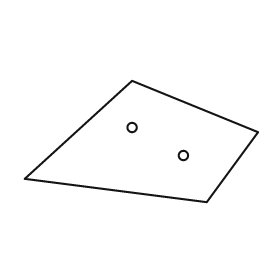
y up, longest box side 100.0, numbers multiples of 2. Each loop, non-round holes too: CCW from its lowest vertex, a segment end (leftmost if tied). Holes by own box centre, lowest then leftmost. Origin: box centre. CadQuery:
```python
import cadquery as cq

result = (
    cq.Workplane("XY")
    .moveTo(28.0, -26.0)
    .lineTo(50.0, 4.0)
    .lineTo(-4.0, 26.0)
    .lineTo(-50.0, -16.0)
    .close()
    .moveTo(18.0, -6.0)
    .circle(2.0)
    .moveTo(-4.0, 6.0)
    .circle(2.0)
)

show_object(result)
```